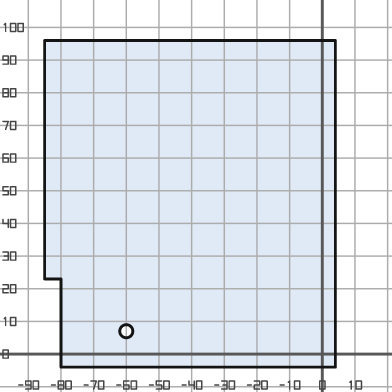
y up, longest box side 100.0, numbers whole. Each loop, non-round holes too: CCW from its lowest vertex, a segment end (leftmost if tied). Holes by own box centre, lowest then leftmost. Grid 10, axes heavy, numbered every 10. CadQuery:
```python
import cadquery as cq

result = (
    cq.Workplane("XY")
    .moveTo(-80.0, -4.0)
    .lineTo(4.0, -4.0)
    .lineTo(4.0, 96.0)
    .lineTo(-85.0, 96.0)
    .lineTo(-85.0, 23.0)
    .lineTo(-80.0, 23.0)
    .close()
    .moveTo(-60.0, 7.0)
    .circle(2.0)
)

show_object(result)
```